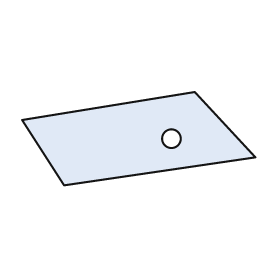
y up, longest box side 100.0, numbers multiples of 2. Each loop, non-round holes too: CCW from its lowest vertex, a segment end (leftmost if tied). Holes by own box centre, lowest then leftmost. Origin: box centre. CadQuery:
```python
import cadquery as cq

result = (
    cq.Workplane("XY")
    .moveTo(-32.0, -20.0)
    .lineTo(50.0, -8.0)
    .lineTo(24.0, 20.0)
    .lineTo(-50.0, 8.0)
    .close()
    .moveTo(14.0, 0.0)
    .circle(4.0)
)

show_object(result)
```